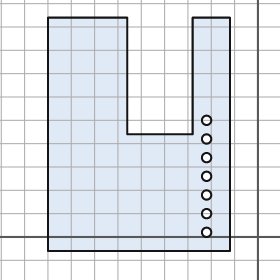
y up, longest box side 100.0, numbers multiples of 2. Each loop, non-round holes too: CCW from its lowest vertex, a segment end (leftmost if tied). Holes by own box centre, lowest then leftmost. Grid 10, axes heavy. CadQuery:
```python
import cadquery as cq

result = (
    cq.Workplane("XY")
    .moveTo(-90.0, -6.0)
    .lineTo(-12.0, -6.0)
    .lineTo(-12.0, 94.0)
    .lineTo(-28.0, 94.0)
    .lineTo(-28.0, 44.0)
    .lineTo(-56.0, 44.0)
    .lineTo(-56.0, 94.0)
    .lineTo(-90.0, 94.0)
    .close()
    .moveTo(-22.0, 2.0)
    .circle(2.0)
    .moveTo(-22.0, 10.0)
    .circle(2.0)
    .moveTo(-22.0, 18.0)
    .circle(2.0)
    .moveTo(-22.0, 26.0)
    .circle(2.0)
    .moveTo(-22.0, 34.0)
    .circle(2.0)
    .moveTo(-22.0, 42.0)
    .circle(2.0)
    .moveTo(-22.0, 50.0)
    .circle(2.0)
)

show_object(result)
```